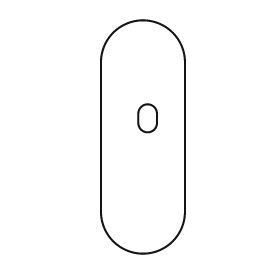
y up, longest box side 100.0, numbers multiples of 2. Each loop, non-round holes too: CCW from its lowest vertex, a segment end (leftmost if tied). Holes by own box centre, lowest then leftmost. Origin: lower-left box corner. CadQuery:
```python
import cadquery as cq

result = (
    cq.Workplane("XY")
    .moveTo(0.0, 18.0)
    .threePointArc((18.0, 0.0), (36.0, 18.0))
    .lineTo(36.0, 82.0)
    .threePointArc((18.0, 100.0), (0.0, 82.0))
    .close()
    .moveTo(16.0, 56.0)
    .threePointArc((20.0, 52.0), (24.0, 56.0))
    .lineTo(24.0, 60.0)
    .threePointArc((20.0, 64.0), (16.0, 60.0))
    .close()
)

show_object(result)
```